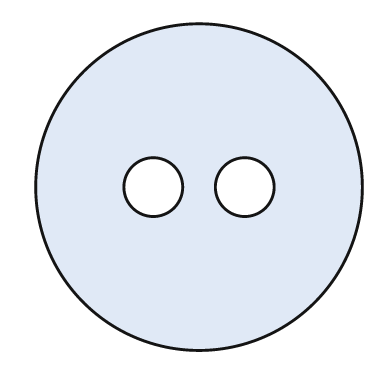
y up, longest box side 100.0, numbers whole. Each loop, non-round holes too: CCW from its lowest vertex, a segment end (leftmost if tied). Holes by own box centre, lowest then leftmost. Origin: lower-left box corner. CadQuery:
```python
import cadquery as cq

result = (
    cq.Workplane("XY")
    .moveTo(50.0, 50.0)
    .circle(50.0)
    .moveTo(36.0, 50.0)
    .circle(9.0)
    .moveTo(64.0, 50.0)
    .circle(9.0)
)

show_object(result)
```